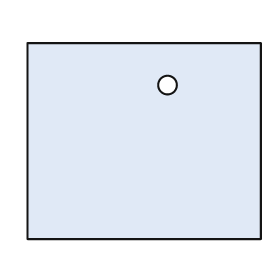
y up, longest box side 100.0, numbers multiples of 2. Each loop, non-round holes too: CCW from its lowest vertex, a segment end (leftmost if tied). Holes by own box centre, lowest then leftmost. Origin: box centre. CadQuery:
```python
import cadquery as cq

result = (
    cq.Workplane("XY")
    .moveTo(-50.0, -42.0)
    .lineTo(50.0, -42.0)
    .lineTo(50.0, 42.0)
    .lineTo(-50.0, 42.0)
    .close()
    .moveTo(10.0, 24.0)
    .circle(4.0)
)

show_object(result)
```